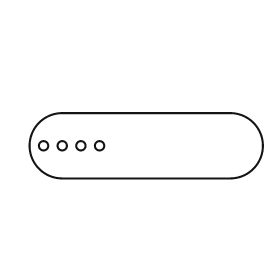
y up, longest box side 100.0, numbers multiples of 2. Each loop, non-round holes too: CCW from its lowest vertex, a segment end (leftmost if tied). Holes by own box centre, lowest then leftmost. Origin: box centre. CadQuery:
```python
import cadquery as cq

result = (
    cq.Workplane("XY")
    .moveTo(-36.0, -14.0)
    .lineTo(36.0, -14.0)
    .threePointArc((50.0, 0.0), (36.0, 14.0))
    .lineTo(-36.0, 14.0)
    .threePointArc((-50.0, 0.0), (-36.0, -14.0))
    .close()
    .moveTo(-44.0, 0.0)
    .circle(2.0)
    .moveTo(-36.0, 0.0)
    .circle(2.0)
    .moveTo(-28.0, 0.0)
    .circle(2.0)
    .moveTo(-20.0, 0.0)
    .circle(2.0)
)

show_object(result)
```